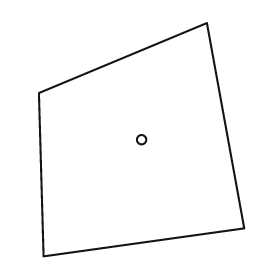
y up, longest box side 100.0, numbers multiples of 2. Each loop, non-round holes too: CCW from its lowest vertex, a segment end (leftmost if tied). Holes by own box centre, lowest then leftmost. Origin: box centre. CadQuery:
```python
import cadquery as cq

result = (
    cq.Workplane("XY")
    .moveTo(-42.0, -50.0)
    .lineTo(44.0, -38.0)
    .lineTo(28.0, 50.0)
    .lineTo(-44.0, 20.0)
    .close()
    .moveTo(0.0, 0.0)
    .circle(2.0)
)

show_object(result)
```